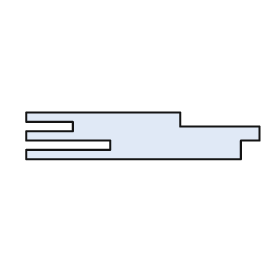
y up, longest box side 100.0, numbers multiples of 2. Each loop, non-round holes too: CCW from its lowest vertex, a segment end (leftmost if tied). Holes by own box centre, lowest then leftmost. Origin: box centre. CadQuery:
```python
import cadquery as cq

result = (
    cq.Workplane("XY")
    .moveTo(-50.0, -10.0)
    .lineTo(42.0, -10.0)
    .lineTo(42.0, -2.0)
    .lineTo(50.0, -2.0)
    .lineTo(50.0, 4.0)
    .lineTo(16.0, 4.0)
    .lineTo(16.0, 10.0)
    .lineTo(-50.0, 10.0)
    .lineTo(-50.0, 6.0)
    .lineTo(-30.0, 6.0)
    .lineTo(-30.0, 2.0)
    .lineTo(-50.0, 2.0)
    .lineTo(-50.0, -2.0)
    .lineTo(-14.0, -2.0)
    .lineTo(-14.0, -6.0)
    .lineTo(-50.0, -6.0)
    .close()
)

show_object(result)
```